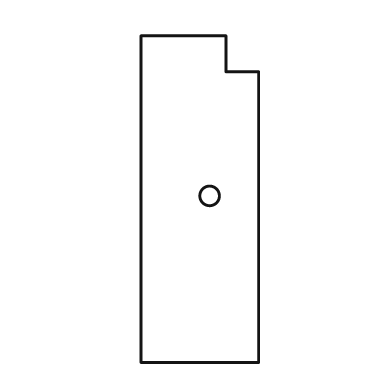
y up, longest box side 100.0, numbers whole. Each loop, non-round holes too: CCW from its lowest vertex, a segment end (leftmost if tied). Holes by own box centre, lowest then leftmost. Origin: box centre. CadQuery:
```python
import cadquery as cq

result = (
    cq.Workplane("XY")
    .moveTo(-18.0, -50.0)
    .lineTo(18.0, -50.0)
    .lineTo(18.0, 39.0)
    .lineTo(8.0, 39.0)
    .lineTo(8.0, 50.0)
    .lineTo(-18.0, 50.0)
    .close()
    .moveTo(3.0, 1.0)
    .circle(3.0)
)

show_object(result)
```